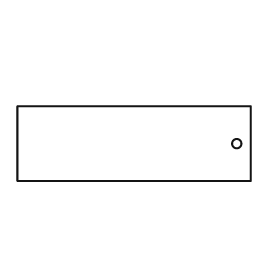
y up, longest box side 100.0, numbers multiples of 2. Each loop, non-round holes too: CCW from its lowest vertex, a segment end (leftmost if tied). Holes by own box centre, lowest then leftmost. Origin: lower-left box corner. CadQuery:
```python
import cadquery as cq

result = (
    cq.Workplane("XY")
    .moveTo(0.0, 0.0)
    .lineTo(100.0, 0.0)
    .lineTo(100.0, 32.0)
    .lineTo(0.0, 32.0)
    .close()
    .moveTo(94.0, 16.0)
    .circle(2.0)
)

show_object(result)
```